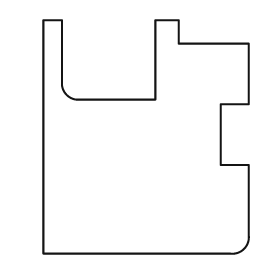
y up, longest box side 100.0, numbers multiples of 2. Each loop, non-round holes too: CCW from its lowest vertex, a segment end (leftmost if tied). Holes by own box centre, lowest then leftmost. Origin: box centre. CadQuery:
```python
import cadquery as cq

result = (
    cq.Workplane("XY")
    .moveTo(-44.0, -50.0)
    .lineTo(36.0, -50.0)
    .threePointArc((42.0, -48.0), (44.0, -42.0))
    .lineTo(44.0, -12.0)
    .lineTo(32.0, -12.0)
    .lineTo(32.0, 14.0)
    .lineTo(44.0, 14.0)
    .lineTo(44.0, 40.0)
    .lineTo(14.0, 40.0)
    .lineTo(14.0, 50.0)
    .lineTo(4.0, 50.0)
    .lineTo(4.0, 16.0)
    .lineTo(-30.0, 16.0)
    .threePointArc((-34.0, 18.0), (-36.0, 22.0))
    .lineTo(-36.0, 50.0)
    .lineTo(-44.0, 50.0)
    .close()
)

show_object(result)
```